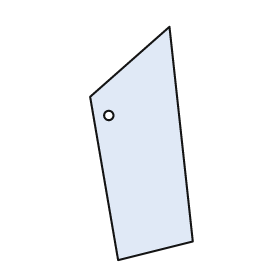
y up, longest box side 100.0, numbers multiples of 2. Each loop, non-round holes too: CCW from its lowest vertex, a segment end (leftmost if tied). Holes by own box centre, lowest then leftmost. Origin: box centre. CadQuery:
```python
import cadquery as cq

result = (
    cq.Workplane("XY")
    .moveTo(-10.0, -50.0)
    .lineTo(22.0, -42.0)
    .lineTo(12.0, 50.0)
    .lineTo(-22.0, 20.0)
    .close()
    .moveTo(-14.0, 12.0)
    .circle(2.0)
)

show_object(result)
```